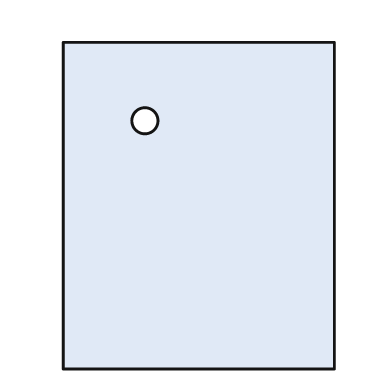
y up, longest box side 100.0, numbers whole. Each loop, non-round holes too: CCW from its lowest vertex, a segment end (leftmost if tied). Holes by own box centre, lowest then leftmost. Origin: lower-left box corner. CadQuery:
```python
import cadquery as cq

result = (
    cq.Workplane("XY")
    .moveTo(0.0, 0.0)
    .lineTo(83.0, 0.0)
    .lineTo(83.0, 100.0)
    .lineTo(0.0, 100.0)
    .close()
    .moveTo(25.0, 76.0)
    .circle(4.0)
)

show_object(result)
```